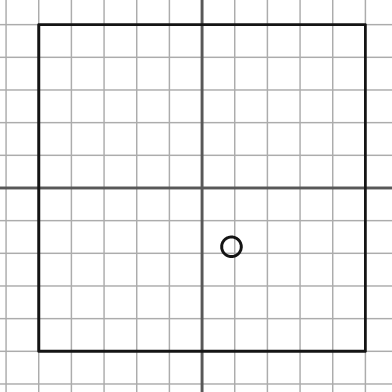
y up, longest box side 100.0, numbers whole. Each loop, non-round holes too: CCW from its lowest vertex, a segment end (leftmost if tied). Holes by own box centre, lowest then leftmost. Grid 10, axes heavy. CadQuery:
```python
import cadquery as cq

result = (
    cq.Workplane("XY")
    .moveTo(-50.0, -50.0)
    .lineTo(50.0, -50.0)
    .lineTo(50.0, 50.0)
    .lineTo(-50.0, 50.0)
    .close()
    .moveTo(9.0, -18.0)
    .circle(3.0)
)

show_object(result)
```